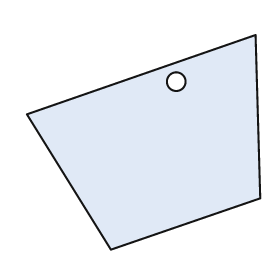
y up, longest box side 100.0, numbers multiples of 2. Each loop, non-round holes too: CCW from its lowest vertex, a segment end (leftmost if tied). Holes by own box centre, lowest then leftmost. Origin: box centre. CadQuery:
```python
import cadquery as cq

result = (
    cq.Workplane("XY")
    .moveTo(-14.0, -46.0)
    .lineTo(50.0, -24.0)
    .lineTo(48.0, 46.0)
    .lineTo(-50.0, 12.0)
    .close()
    .moveTo(14.0, 26.0)
    .circle(4.0)
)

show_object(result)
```